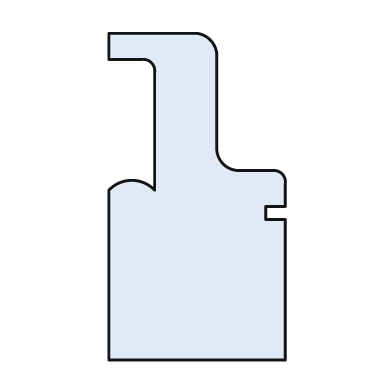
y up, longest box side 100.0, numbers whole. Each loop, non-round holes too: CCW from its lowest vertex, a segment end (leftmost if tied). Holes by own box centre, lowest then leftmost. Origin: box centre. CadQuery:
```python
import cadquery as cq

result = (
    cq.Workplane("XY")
    .moveTo(-27.0, -50.0)
    .lineTo(27.0, -50.0)
    .lineTo(27.0, -7.0)
    .lineTo(21.0, -7.0)
    .lineTo(21.0, -3.0)
    .lineTo(27.0, -3.0)
    .lineTo(27.0, 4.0)
    .threePointArc((26.0, 7.0), (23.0, 8.0))
    .lineTo(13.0, 8.0)
    .threePointArc((8.0, 10.0), (6.0, 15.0))
    .lineTo(6.0, 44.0)
    .threePointArc((4.0, 48.0), (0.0, 50.0))
    .lineTo(-27.0, 50.0)
    .lineTo(-27.0, 42.0)
    .lineTo(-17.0, 42.0)
    .threePointArc((-14.0, 41.0), (-13.0, 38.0))
    .lineTo(-13.0, 2.0)
    .threePointArc((-20.0, 5.0), (-27.0, 2.0))
    .close()
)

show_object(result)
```